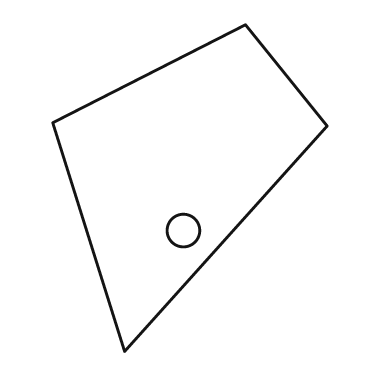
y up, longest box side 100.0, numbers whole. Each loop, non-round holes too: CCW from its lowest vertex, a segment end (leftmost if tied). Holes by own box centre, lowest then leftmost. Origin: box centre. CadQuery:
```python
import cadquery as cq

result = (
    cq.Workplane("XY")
    .moveTo(-20.0, -50.0)
    .lineTo(42.0, 19.0)
    .lineTo(17.0, 50.0)
    .lineTo(-42.0, 20.0)
    .close()
    .moveTo(-2.0, -13.0)
    .circle(5.0)
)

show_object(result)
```